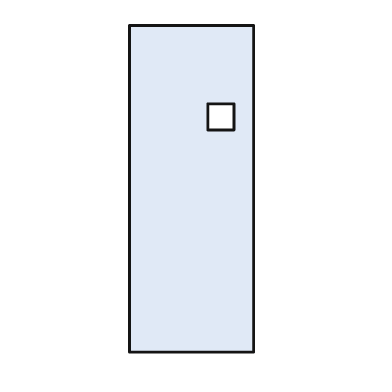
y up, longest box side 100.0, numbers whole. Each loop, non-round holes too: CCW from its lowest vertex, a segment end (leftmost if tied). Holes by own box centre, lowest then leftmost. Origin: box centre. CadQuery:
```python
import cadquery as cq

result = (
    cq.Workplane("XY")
    .moveTo(-19.0, -50.0)
    .lineTo(19.0, -50.0)
    .lineTo(19.0, 50.0)
    .lineTo(-19.0, 50.0)
    .close()
    .moveTo(5.0, 18.0)
    .lineTo(13.0, 18.0)
    .lineTo(13.0, 26.0)
    .lineTo(5.0, 26.0)
    .close()
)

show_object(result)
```